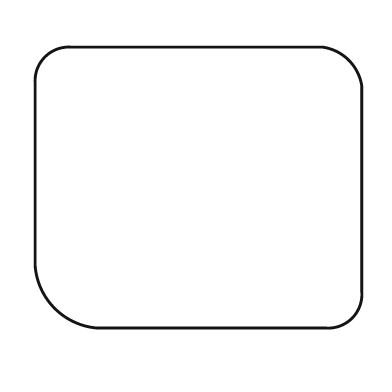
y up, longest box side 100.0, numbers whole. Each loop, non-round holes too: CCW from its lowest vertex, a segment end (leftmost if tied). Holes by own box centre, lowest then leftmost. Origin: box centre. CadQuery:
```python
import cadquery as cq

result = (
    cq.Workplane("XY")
    .moveTo(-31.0, -43.0)
    .lineTo(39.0, -43.0)
    .threePointArc((47.0, -40.0), (50.0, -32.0))
    .lineTo(50.0, 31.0)
    .threePointArc((46.0, 39.0), (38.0, 43.0))
    .lineTo(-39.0, 43.0)
    .threePointArc((-47.0, 40.0), (-50.0, 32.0))
    .lineTo(-50.0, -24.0)
    .threePointArc((-44.0, -37.0), (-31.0, -43.0))
    .close()
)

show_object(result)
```